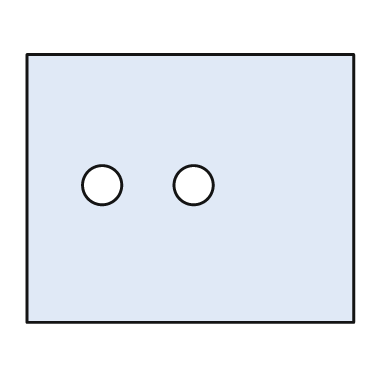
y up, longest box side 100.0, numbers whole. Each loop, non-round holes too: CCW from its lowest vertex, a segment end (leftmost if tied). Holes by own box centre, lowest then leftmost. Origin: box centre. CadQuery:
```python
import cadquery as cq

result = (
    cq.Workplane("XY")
    .moveTo(-50.0, -41.0)
    .lineTo(50.0, -41.0)
    .lineTo(50.0, 41.0)
    .lineTo(-50.0, 41.0)
    .close()
    .moveTo(-27.0, 1.0)
    .circle(6.0)
    .moveTo(1.0, 1.0)
    .circle(6.0)
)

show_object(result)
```